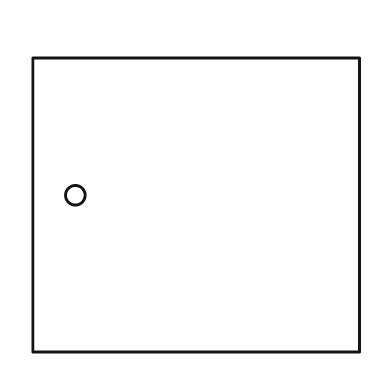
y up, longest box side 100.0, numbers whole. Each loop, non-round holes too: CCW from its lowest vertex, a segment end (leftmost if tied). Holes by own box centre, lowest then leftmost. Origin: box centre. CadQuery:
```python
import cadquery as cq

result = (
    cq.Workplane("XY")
    .moveTo(-50.0, -45.0)
    .lineTo(50.0, -45.0)
    .lineTo(50.0, 45.0)
    .lineTo(-50.0, 45.0)
    .close()
    .moveTo(-37.0, 3.0)
    .circle(3.0)
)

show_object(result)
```